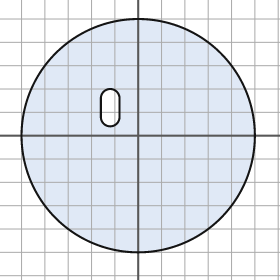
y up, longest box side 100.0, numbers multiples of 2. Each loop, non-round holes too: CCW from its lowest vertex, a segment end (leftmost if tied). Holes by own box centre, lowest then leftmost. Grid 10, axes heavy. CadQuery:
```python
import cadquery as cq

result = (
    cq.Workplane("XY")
    .moveTo(0.0, 0.0)
    .circle(50.0)
    .moveTo(-16.0, 8.0)
    .threePointArc((-12.0, 4.0), (-8.0, 8.0))
    .lineTo(-8.0, 16.0)
    .threePointArc((-12.0, 20.0), (-16.0, 16.0))
    .close()
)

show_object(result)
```